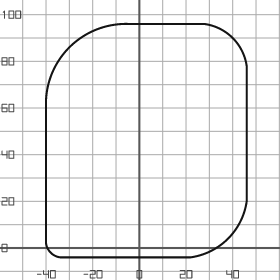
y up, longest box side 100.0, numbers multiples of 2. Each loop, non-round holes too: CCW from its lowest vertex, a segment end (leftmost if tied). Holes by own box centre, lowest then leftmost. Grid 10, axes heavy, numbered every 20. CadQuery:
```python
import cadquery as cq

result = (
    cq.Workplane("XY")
    .moveTo(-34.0, -4.0)
    .lineTo(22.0, -4.0)
    .threePointArc((38.0, 4.0), (46.0, 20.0))
    .lineTo(46.0, 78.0)
    .threePointArc((40.0, 90.0), (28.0, 96.0))
    .lineTo(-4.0, 96.0)
    .threePointArc((-30.0, 86.0), (-40.0, 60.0))
    .lineTo(-40.0, 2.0)
    .threePointArc((-38.0, -2.0), (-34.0, -4.0))
    .close()
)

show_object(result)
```